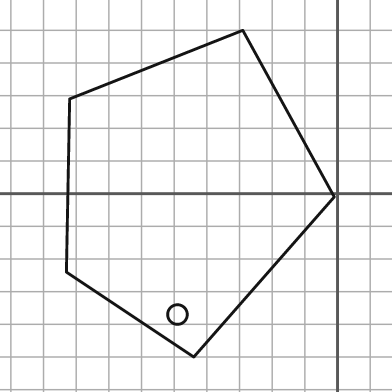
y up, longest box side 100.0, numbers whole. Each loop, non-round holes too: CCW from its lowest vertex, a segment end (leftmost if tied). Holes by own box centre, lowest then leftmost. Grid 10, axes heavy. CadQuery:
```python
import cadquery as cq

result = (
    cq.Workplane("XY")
    .moveTo(-44.0, -50.0)
    .lineTo(-1.0, -1.0)
    .lineTo(-29.0, 50.0)
    .lineTo(-82.0, 29.0)
    .lineTo(-83.0, -24.0)
    .close()
    .moveTo(-49.0, -37.0)
    .circle(3.0)
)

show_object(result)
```